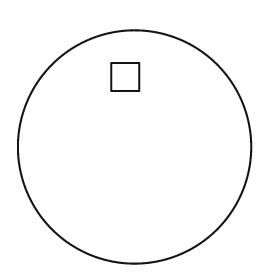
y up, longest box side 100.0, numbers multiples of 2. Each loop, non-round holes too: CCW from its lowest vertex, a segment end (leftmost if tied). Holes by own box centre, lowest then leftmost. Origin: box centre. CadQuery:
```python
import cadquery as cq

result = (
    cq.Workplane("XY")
    .moveTo(0.0, 0.0)
    .circle(50.0)
    .moveTo(-10.0, 24.0)
    .lineTo(2.0, 24.0)
    .lineTo(2.0, 36.0)
    .lineTo(-10.0, 36.0)
    .close()
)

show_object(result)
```